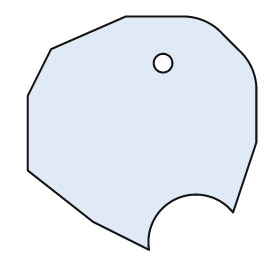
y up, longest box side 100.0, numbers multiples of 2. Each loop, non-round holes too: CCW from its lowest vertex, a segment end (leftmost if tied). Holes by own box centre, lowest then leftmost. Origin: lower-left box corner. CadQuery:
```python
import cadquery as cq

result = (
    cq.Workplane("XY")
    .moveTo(52.0, 0.0)
    .threePointArc((64.0, 22.0), (88.0, 16.0))
    .lineTo(98.0, 46.0)
    .lineTo(98.0, 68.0)
    .threePointArc((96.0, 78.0), (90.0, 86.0))
    .lineTo(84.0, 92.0)
    .threePointArc((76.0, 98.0), (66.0, 100.0))
    .lineTo(42.0, 100.0)
    .lineTo(10.0, 86.0)
    .lineTo(0.0, 66.0)
    .lineTo(0.0, 34.0)
    .lineTo(28.0, 12.0)
    .close()
    .moveTo(58.0, 80.0)
    .circle(4.0)
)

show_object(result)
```